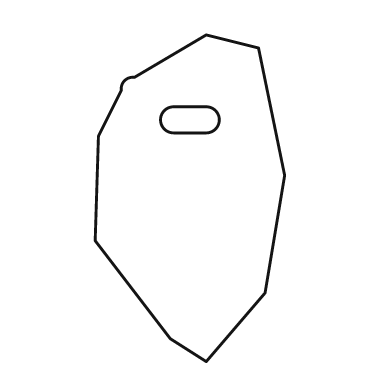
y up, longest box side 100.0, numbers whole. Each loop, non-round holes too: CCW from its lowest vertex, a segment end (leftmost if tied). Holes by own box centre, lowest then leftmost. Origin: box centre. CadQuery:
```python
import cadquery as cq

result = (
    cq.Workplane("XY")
    .moveTo(5.0, -50.0)
    .lineTo(23.0, -29.0)
    .lineTo(29.0, 7.0)
    .lineTo(21.0, 46.0)
    .lineTo(5.0, 50.0)
    .lineTo(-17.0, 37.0)
    .threePointArc((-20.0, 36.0), (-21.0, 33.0))
    .lineTo(-28.0, 19.0)
    .lineTo(-29.0, -13.0)
    .lineTo(-6.0, -43.0)
    .close()
    .moveTo(-5.0, 20.0)
    .lineTo(5.0, 20.0)
    .threePointArc((9.0, 24.0), (5.0, 28.0))
    .lineTo(-5.0, 28.0)
    .threePointArc((-9.0, 24.0), (-5.0, 20.0))
    .close()
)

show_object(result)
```